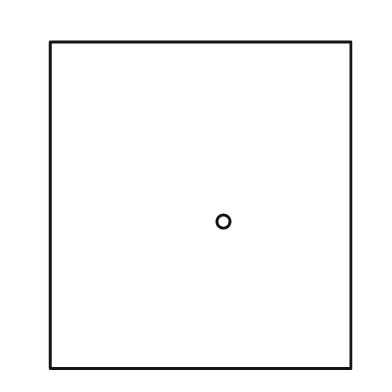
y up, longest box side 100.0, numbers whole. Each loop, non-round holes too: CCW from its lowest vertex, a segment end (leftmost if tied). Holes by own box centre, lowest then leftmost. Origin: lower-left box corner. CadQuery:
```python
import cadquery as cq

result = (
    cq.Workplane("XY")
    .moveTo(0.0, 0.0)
    .lineTo(92.0, 0.0)
    .lineTo(92.0, 100.0)
    .lineTo(0.0, 100.0)
    .close()
    .moveTo(53.0, 45.0)
    .circle(2.0)
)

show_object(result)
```